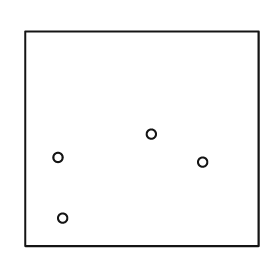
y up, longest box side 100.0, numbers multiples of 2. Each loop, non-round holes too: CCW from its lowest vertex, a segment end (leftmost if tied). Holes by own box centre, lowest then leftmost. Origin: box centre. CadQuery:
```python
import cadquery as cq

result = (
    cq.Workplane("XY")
    .moveTo(-50.0, -46.0)
    .lineTo(50.0, -46.0)
    .lineTo(50.0, 46.0)
    .lineTo(-50.0, 46.0)
    .close()
    .moveTo(-34.0, -34.0)
    .circle(2.0)
    .moveTo(26.0, -10.0)
    .circle(2.0)
    .moveTo(-36.0, -8.0)
    .circle(2.0)
    .moveTo(4.0, 2.0)
    .circle(2.0)
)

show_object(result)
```